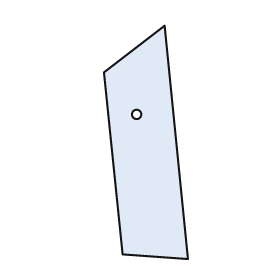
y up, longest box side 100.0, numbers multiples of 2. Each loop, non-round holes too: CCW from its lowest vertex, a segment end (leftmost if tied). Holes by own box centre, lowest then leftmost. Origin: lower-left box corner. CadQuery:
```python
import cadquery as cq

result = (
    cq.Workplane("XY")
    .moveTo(36.0, 0.0)
    .lineTo(26.0, 100.0)
    .lineTo(0.0, 80.0)
    .lineTo(8.0, 2.0)
    .close()
    .moveTo(14.0, 62.0)
    .circle(2.0)
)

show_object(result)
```